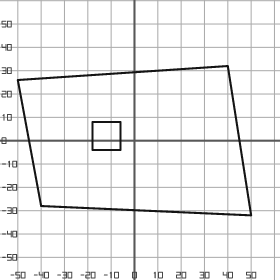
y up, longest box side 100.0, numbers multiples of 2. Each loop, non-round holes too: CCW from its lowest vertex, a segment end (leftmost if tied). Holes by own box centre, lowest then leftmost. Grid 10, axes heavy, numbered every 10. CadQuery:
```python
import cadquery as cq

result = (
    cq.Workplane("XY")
    .moveTo(50.0, -32.0)
    .lineTo(40.0, 32.0)
    .lineTo(-50.0, 26.0)
    .lineTo(-40.0, -28.0)
    .close()
    .moveTo(-18.0, -4.0)
    .lineTo(-6.0, -4.0)
    .lineTo(-6.0, 8.0)
    .lineTo(-18.0, 8.0)
    .close()
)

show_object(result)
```